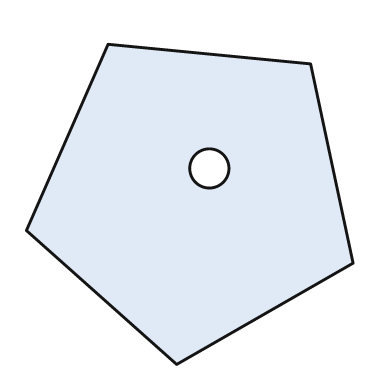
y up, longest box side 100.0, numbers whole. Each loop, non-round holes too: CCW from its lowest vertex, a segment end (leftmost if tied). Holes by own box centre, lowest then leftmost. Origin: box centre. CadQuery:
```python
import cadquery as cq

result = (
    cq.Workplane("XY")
    .moveTo(-4.0, -49.0)
    .lineTo(50.0, -18.0)
    .lineTo(37.0, 43.0)
    .lineTo(-25.0, 49.0)
    .lineTo(-50.0, -8.0)
    .close()
    .moveTo(6.0, 11.0)
    .circle(6.0)
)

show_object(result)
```